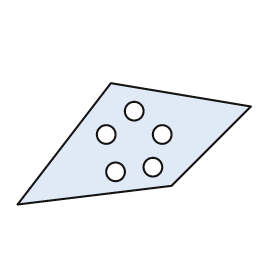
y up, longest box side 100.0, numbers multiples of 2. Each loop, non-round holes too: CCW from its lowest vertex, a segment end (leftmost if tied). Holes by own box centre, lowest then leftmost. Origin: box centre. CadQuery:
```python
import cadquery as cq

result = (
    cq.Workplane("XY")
    .moveTo(-50.0, -26.0)
    .lineTo(16.0, -18.0)
    .lineTo(50.0, 16.0)
    .lineTo(-10.0, 26.0)
    .close()
    .moveTo(-8.0, -12.0)
    .circle(4.0)
    .moveTo(8.0, -10.0)
    .circle(4.0)
    .moveTo(-12.0, 4.0)
    .circle(4.0)
    .moveTo(12.0, 4.0)
    .circle(4.0)
    .moveTo(0.0, 14.0)
    .circle(4.0)
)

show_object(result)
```